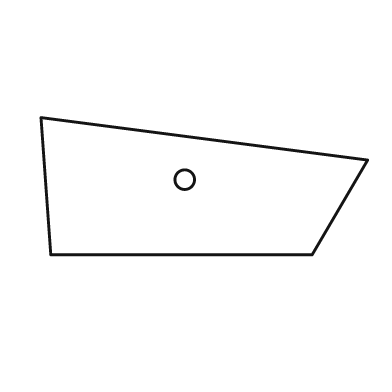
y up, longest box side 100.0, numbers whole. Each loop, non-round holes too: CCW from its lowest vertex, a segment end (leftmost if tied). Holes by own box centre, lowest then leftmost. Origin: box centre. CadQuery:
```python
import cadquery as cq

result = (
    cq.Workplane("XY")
    .moveTo(-47.0, -21.0)
    .lineTo(33.0, -21.0)
    .lineTo(50.0, 8.0)
    .lineTo(-50.0, 21.0)
    .close()
    .moveTo(-6.0, 2.0)
    .circle(3.0)
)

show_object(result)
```